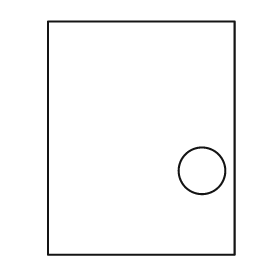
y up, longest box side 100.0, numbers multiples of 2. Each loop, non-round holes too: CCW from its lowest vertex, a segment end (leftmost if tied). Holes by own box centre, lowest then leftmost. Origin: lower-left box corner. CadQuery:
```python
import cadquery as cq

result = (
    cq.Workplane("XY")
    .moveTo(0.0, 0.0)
    .lineTo(80.0, 0.0)
    .lineTo(80.0, 100.0)
    .lineTo(0.0, 100.0)
    .close()
    .moveTo(66.0, 36.0)
    .circle(10.0)
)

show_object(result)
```